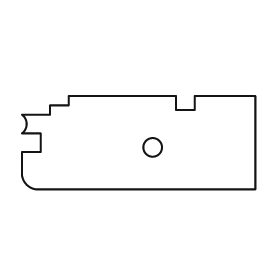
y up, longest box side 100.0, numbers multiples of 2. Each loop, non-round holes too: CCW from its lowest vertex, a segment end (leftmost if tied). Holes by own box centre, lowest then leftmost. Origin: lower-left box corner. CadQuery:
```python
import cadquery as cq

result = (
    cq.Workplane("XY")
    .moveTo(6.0, 0.0)
    .lineTo(100.0, 0.0)
    .lineTo(100.0, 40.0)
    .lineTo(74.0, 40.0)
    .lineTo(74.0, 34.0)
    .lineTo(66.0, 34.0)
    .lineTo(66.0, 40.0)
    .lineTo(20.0, 40.0)
    .lineTo(20.0, 36.0)
    .lineTo(12.0, 36.0)
    .lineTo(12.0, 32.0)
    .lineTo(0.0, 32.0)
    .threePointArc((2.0, 28.0), (0.0, 24.0))
    .lineTo(8.0, 24.0)
    .lineTo(8.0, 16.0)
    .lineTo(0.0, 16.0)
    .lineTo(0.0, 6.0)
    .threePointArc((2.0, 2.0), (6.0, 0.0))
    .close()
    .moveTo(56.0, 18.0)
    .circle(4.0)
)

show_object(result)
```